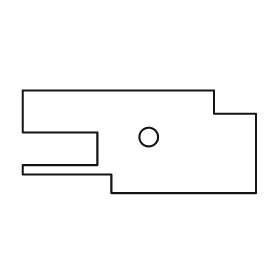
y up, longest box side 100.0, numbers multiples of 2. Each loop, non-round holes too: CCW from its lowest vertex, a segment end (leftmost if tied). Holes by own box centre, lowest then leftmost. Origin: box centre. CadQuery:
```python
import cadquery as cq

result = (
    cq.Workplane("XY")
    .moveTo(-12.0, -22.0)
    .lineTo(50.0, -22.0)
    .lineTo(50.0, 12.0)
    .lineTo(32.0, 12.0)
    .lineTo(32.0, 22.0)
    .lineTo(-50.0, 22.0)
    .lineTo(-50.0, 4.0)
    .lineTo(-18.0, 4.0)
    .lineTo(-18.0, -10.0)
    .lineTo(-50.0, -10.0)
    .lineTo(-50.0, -14.0)
    .lineTo(-12.0, -14.0)
    .close()
    .moveTo(4.0, 2.0)
    .circle(4.0)
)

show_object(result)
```